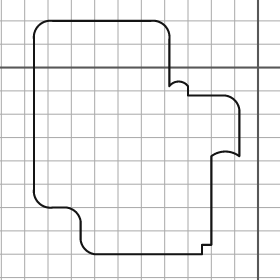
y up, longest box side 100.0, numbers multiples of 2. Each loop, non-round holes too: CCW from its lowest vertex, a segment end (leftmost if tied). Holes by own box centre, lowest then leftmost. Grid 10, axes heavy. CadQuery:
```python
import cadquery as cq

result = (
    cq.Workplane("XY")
    .moveTo(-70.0, -80.0)
    .lineTo(-24.0, -80.0)
    .lineTo(-24.0, -76.0)
    .lineTo(-20.0, -76.0)
    .lineTo(-20.0, -38.0)
    .threePointArc((-14.0, -36.0), (-8.0, -38.0))
    .lineTo(-8.0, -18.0)
    .threePointArc((-10.0, -14.0), (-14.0, -12.0))
    .lineTo(-30.0, -12.0)
    .lineTo(-30.0, -8.0)
    .threePointArc((-34.0, -6.0), (-38.0, -8.0))
    .lineTo(-38.0, 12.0)
    .threePointArc((-40.0, 18.0), (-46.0, 20.0))
    .lineTo(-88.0, 20.0)
    .threePointArc((-94.0, 18.0), (-96.0, 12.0))
    .lineTo(-96.0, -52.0)
    .threePointArc((-94.0, -58.0), (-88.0, -60.0))
    .lineTo(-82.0, -60.0)
    .threePointArc((-78.0, -62.0), (-76.0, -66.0))
    .lineTo(-76.0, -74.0)
    .threePointArc((-74.0, -78.0), (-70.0, -80.0))
    .close()
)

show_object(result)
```